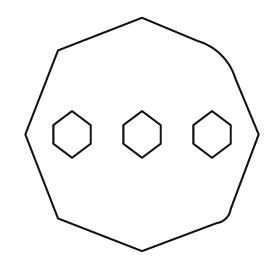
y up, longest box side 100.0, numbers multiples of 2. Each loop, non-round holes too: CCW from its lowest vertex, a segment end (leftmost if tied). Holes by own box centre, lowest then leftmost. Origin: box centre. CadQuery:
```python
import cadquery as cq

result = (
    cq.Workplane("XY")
    .moveTo(0.0, -50.0)
    .lineTo(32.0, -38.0)
    .threePointArc((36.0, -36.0), (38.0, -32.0))
    .lineTo(50.0, 0.0)
    .lineTo(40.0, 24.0)
    .threePointArc((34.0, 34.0), (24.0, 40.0))
    .lineTo(0.0, 50.0)
    .lineTo(-36.0, 36.0)
    .lineTo(-50.0, 0.0)
    .lineTo(-36.0, -36.0)
    .close()
    .moveTo(-30.0, -10.0)
    .lineTo(-22.0, -4.0)
    .lineTo(-22.0, 4.0)
    .lineTo(-30.0, 10.0)
    .lineTo(-38.0, 4.0)
    .lineTo(-38.0, -4.0)
    .close()
    .moveTo(0.0, -10.0)
    .lineTo(8.0, -4.0)
    .lineTo(8.0, 4.0)
    .lineTo(0.0, 10.0)
    .lineTo(-8.0, 4.0)
    .lineTo(-8.0, -4.0)
    .close()
    .moveTo(30.0, -10.0)
    .lineTo(38.0, -4.0)
    .lineTo(38.0, 4.0)
    .lineTo(30.0, 10.0)
    .lineTo(22.0, 4.0)
    .lineTo(22.0, -4.0)
    .close()
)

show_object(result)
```